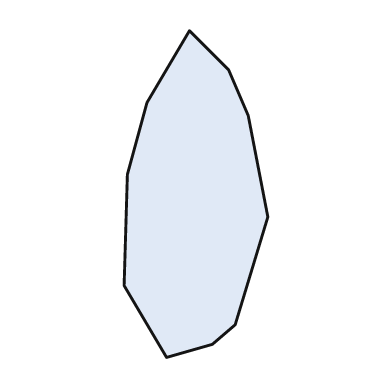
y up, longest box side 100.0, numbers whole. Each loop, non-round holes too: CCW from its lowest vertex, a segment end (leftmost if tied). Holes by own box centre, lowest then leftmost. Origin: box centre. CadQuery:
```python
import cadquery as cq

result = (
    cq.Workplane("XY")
    .moveTo(-9.0, -50.0)
    .lineTo(5.0, -46.0)
    .lineTo(12.0, -40.0)
    .lineTo(22.0, -7.0)
    .lineTo(16.0, 24.0)
    .lineTo(10.0, 38.0)
    .lineTo(-2.0, 50.0)
    .lineTo(-15.0, 28.0)
    .lineTo(-21.0, 6.0)
    .lineTo(-22.0, -28.0)
    .close()
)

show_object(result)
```